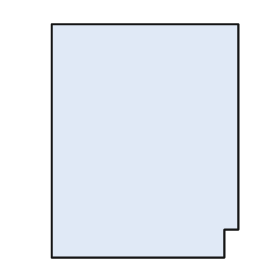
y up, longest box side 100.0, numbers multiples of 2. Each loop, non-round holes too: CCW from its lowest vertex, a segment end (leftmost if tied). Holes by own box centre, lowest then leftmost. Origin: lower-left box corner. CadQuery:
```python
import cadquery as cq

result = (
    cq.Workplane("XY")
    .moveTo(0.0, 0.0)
    .lineTo(74.0, 0.0)
    .lineTo(74.0, 12.0)
    .lineTo(80.0, 12.0)
    .lineTo(80.0, 100.0)
    .lineTo(0.0, 100.0)
    .close()
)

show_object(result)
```